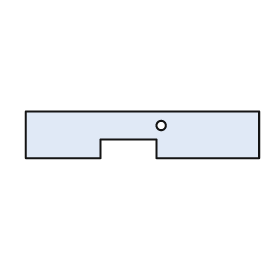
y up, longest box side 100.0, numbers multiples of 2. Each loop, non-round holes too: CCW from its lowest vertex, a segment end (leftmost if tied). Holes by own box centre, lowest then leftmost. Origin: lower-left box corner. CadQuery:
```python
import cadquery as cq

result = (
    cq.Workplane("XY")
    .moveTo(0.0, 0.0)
    .lineTo(32.0, 0.0)
    .lineTo(32.0, 8.0)
    .lineTo(56.0, 8.0)
    .lineTo(56.0, 0.0)
    .lineTo(100.0, 0.0)
    .lineTo(100.0, 20.0)
    .lineTo(0.0, 20.0)
    .close()
    .moveTo(58.0, 14.0)
    .circle(2.0)
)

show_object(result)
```